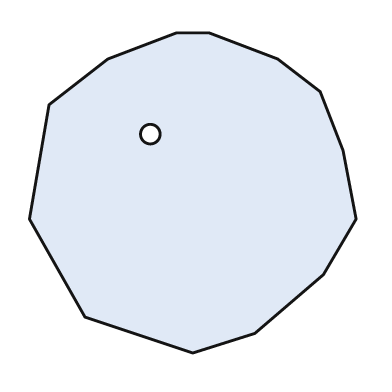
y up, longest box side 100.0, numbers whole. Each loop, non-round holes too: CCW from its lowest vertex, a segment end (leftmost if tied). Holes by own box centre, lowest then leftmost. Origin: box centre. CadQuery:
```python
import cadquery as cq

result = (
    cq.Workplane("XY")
    .moveTo(0.0, -49.0)
    .lineTo(19.0, -43.0)
    .lineTo(40.0, -25.0)
    .lineTo(50.0, -8.0)
    .lineTo(46.0, 13.0)
    .lineTo(39.0, 31.0)
    .lineTo(26.0, 41.0)
    .lineTo(5.0, 49.0)
    .lineTo(-5.0, 49.0)
    .lineTo(-26.0, 41.0)
    .lineTo(-44.0, 27.0)
    .lineTo(-50.0, -8.0)
    .lineTo(-33.0, -38.0)
    .close()
    .moveTo(-13.0, 18.0)
    .circle(3.0)
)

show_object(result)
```